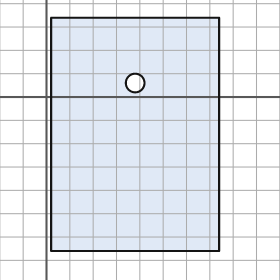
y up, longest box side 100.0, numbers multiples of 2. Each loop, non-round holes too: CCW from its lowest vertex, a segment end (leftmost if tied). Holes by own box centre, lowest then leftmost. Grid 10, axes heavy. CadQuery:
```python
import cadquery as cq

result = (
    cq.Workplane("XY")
    .moveTo(2.0, -66.0)
    .lineTo(74.0, -66.0)
    .lineTo(74.0, 34.0)
    .lineTo(2.0, 34.0)
    .close()
    .moveTo(38.0, 6.0)
    .circle(4.0)
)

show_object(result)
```